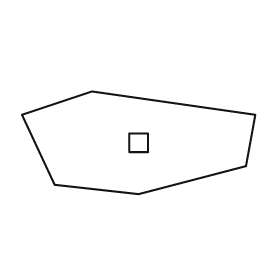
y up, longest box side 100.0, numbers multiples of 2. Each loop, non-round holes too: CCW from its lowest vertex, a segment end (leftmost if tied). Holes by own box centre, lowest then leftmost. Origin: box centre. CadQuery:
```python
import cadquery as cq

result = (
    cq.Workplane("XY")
    .moveTo(0.0, -22.0)
    .lineTo(46.0, -10.0)
    .lineTo(50.0, 12.0)
    .lineTo(-20.0, 22.0)
    .lineTo(-50.0, 12.0)
    .lineTo(-36.0, -18.0)
    .close()
    .moveTo(-4.0, -4.0)
    .lineTo(4.0, -4.0)
    .lineTo(4.0, 4.0)
    .lineTo(-4.0, 4.0)
    .close()
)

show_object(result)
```